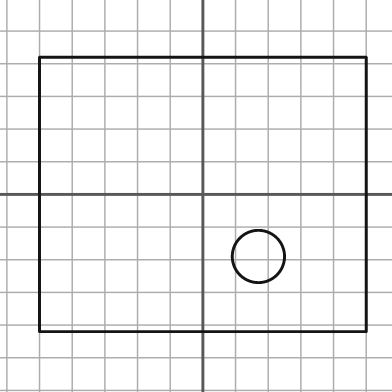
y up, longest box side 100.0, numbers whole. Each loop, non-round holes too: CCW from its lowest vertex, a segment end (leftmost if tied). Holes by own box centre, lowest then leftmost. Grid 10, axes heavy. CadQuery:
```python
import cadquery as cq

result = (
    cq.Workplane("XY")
    .moveTo(-50.0, -42.0)
    .lineTo(50.0, -42.0)
    .lineTo(50.0, 42.0)
    .lineTo(-50.0, 42.0)
    .close()
    .moveTo(17.0, -19.0)
    .circle(8.0)
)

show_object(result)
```